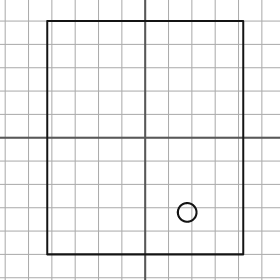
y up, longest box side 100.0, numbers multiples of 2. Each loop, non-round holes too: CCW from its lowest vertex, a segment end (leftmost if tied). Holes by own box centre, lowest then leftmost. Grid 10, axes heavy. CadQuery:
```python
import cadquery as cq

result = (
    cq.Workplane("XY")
    .moveTo(-42.0, -50.0)
    .lineTo(42.0, -50.0)
    .lineTo(42.0, 50.0)
    .lineTo(-42.0, 50.0)
    .close()
    .moveTo(18.0, -32.0)
    .circle(4.0)
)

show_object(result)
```